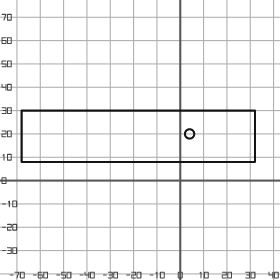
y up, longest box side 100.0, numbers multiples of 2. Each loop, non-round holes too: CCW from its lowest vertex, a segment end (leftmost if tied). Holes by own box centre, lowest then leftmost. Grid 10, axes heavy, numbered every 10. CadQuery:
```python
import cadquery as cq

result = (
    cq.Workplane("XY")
    .moveTo(-68.0, 8.0)
    .lineTo(32.0, 8.0)
    .lineTo(32.0, 30.0)
    .lineTo(-68.0, 30.0)
    .close()
    .moveTo(4.0, 20.0)
    .circle(2.0)
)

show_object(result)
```